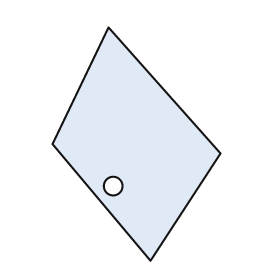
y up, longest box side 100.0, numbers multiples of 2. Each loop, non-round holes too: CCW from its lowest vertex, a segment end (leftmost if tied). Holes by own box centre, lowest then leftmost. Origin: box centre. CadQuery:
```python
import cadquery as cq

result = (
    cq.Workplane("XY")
    .moveTo(6.0, -50.0)
    .lineTo(36.0, -4.0)
    .lineTo(-12.0, 50.0)
    .lineTo(-36.0, 0.0)
    .close()
    .moveTo(-10.0, -18.0)
    .circle(4.0)
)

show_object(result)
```